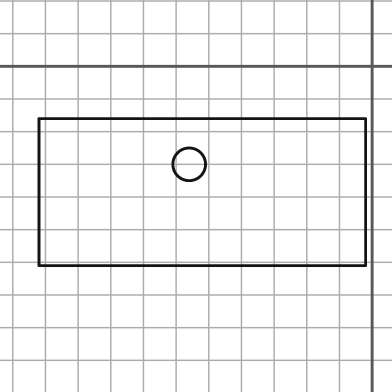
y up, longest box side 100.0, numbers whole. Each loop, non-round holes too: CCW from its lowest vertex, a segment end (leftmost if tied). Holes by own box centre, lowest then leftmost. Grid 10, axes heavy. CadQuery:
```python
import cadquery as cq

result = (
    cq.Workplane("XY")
    .moveTo(-102.0, -61.0)
    .lineTo(-2.0, -61.0)
    .lineTo(-2.0, -16.0)
    .lineTo(-102.0, -16.0)
    .close()
    .moveTo(-56.0, -30.0)
    .circle(5.0)
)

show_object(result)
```